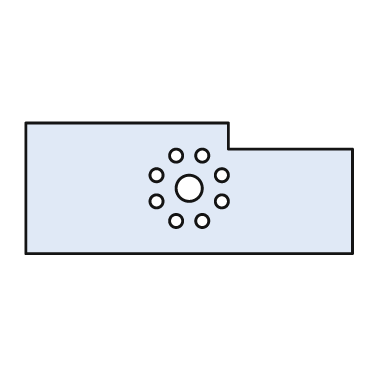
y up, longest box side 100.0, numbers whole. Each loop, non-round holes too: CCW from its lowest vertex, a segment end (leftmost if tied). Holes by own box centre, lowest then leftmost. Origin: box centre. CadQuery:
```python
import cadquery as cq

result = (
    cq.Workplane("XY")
    .moveTo(-50.0, -20.0)
    .lineTo(50.0, -20.0)
    .lineTo(50.0, 12.0)
    .lineTo(12.0, 12.0)
    .lineTo(12.0, 20.0)
    .lineTo(-50.0, 20.0)
    .close()
    .moveTo(-4.0, -10.0)
    .circle(2.0)
    .moveTo(4.0, -10.0)
    .circle(2.0)
    .moveTo(-10.0, -4.0)
    .circle(2.0)
    .moveTo(10.0, -4.0)
    .circle(2.0)
    .moveTo(0.0, 0.0)
    .circle(4.0)
    .moveTo(-10.0, 4.0)
    .circle(2.0)
    .moveTo(10.0, 4.0)
    .circle(2.0)
    .moveTo(-4.0, 10.0)
    .circle(2.0)
    .moveTo(4.0, 10.0)
    .circle(2.0)
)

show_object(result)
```